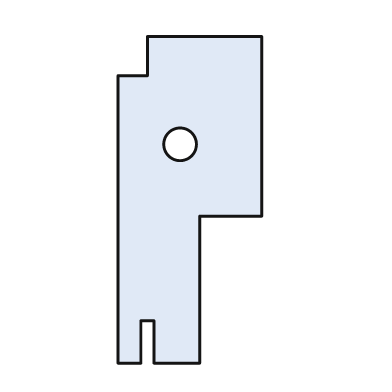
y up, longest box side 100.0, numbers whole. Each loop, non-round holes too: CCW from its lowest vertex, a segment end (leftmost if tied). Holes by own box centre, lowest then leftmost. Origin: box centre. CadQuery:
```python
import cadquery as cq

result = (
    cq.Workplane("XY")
    .moveTo(-22.0, -50.0)
    .lineTo(-15.0, -50.0)
    .lineTo(-15.0, -37.0)
    .lineTo(-11.0, -37.0)
    .lineTo(-11.0, -50.0)
    .lineTo(3.0, -50.0)
    .lineTo(3.0, -5.0)
    .lineTo(22.0, -5.0)
    .lineTo(22.0, 50.0)
    .lineTo(-13.0, 50.0)
    .lineTo(-13.0, 38.0)
    .lineTo(-22.0, 38.0)
    .close()
    .moveTo(-3.0, 17.0)
    .circle(5.0)
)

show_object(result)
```